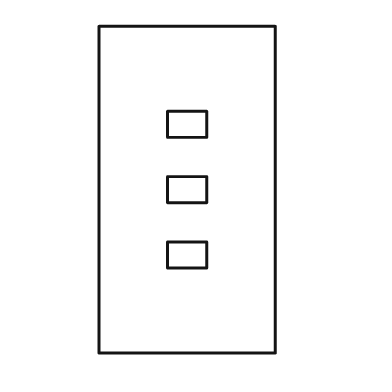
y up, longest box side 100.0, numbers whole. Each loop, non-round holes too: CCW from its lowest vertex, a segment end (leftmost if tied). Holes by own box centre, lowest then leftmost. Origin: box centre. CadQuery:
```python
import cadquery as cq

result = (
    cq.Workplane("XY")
    .moveTo(-27.0, -50.0)
    .lineTo(27.0, -50.0)
    .lineTo(27.0, 50.0)
    .lineTo(-27.0, 50.0)
    .close()
    .moveTo(-6.0, -24.0)
    .lineTo(6.0, -24.0)
    .lineTo(6.0, -16.0)
    .lineTo(-6.0, -16.0)
    .close()
    .moveTo(-6.0, -4.0)
    .lineTo(6.0, -4.0)
    .lineTo(6.0, 4.0)
    .lineTo(-6.0, 4.0)
    .close()
    .moveTo(-6.0, 16.0)
    .lineTo(6.0, 16.0)
    .lineTo(6.0, 24.0)
    .lineTo(-6.0, 24.0)
    .close()
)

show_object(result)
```